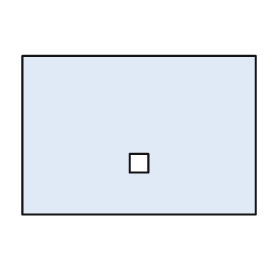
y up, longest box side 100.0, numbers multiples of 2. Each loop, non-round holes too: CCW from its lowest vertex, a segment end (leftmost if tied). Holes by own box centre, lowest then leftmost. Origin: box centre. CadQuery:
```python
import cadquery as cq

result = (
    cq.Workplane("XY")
    .moveTo(-50.0, -34.0)
    .lineTo(50.0, -34.0)
    .lineTo(50.0, 34.0)
    .lineTo(-50.0, 34.0)
    .close()
    .moveTo(-4.0, -16.0)
    .lineTo(4.0, -16.0)
    .lineTo(4.0, -8.0)
    .lineTo(-4.0, -8.0)
    .close()
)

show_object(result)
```